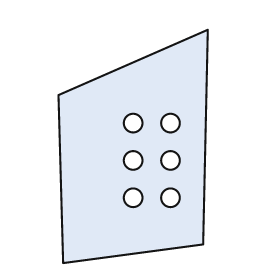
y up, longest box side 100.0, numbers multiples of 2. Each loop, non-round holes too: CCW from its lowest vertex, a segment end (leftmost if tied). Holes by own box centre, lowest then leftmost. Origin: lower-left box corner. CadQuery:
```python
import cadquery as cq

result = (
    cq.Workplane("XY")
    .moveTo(2.0, 0.0)
    .lineTo(62.0, 8.0)
    .lineTo(64.0, 100.0)
    .lineTo(0.0, 72.0)
    .close()
    .moveTo(32.0, 28.0)
    .circle(4.0)
    .moveTo(48.0, 28.0)
    .circle(4.0)
    .moveTo(32.0, 44.0)
    .circle(4.0)
    .moveTo(48.0, 44.0)
    .circle(4.0)
    .moveTo(32.0, 60.0)
    .circle(4.0)
    .moveTo(48.0, 60.0)
    .circle(4.0)
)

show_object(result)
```